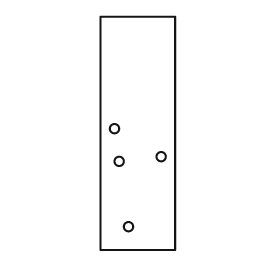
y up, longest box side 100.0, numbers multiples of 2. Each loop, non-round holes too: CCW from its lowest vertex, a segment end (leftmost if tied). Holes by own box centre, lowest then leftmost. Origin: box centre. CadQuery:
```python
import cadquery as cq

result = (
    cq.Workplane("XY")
    .moveTo(-16.0, -50.0)
    .lineTo(16.0, -50.0)
    .lineTo(16.0, 50.0)
    .lineTo(-16.0, 50.0)
    .close()
    .moveTo(-4.0, -40.0)
    .circle(2.0)
    .moveTo(-8.0, -12.0)
    .circle(2.0)
    .moveTo(10.0, -10.0)
    .circle(2.0)
    .moveTo(-10.0, 2.0)
    .circle(2.0)
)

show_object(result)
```